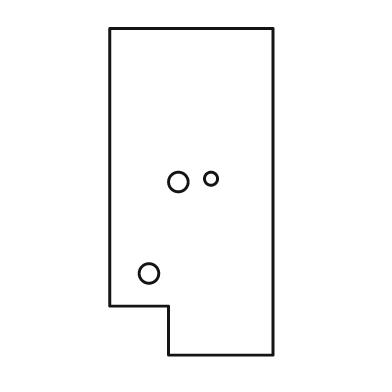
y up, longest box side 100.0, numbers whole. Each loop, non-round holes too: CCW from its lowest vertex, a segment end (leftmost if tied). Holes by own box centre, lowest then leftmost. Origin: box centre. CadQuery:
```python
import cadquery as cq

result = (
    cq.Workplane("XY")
    .moveTo(-7.0, -50.0)
    .lineTo(25.0, -50.0)
    .lineTo(25.0, 50.0)
    .lineTo(-25.0, 50.0)
    .lineTo(-25.0, -35.0)
    .lineTo(-7.0, -35.0)
    .close()
    .moveTo(-13.0, -25.0)
    .circle(3.0)
    .moveTo(-4.0, 3.0)
    .circle(3.0)
    .moveTo(6.0, 4.0)
    .circle(2.0)
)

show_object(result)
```